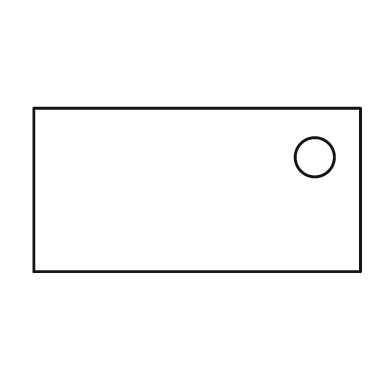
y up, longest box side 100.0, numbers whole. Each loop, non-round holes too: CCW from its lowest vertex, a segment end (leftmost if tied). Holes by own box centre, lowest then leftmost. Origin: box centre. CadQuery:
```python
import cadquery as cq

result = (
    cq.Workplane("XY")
    .moveTo(-50.0, -25.0)
    .lineTo(50.0, -25.0)
    .lineTo(50.0, 25.0)
    .lineTo(-50.0, 25.0)
    .close()
    .moveTo(36.0, 10.0)
    .circle(6.0)
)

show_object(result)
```